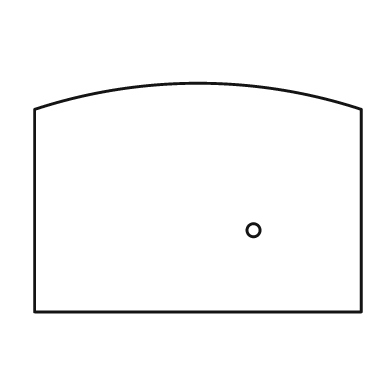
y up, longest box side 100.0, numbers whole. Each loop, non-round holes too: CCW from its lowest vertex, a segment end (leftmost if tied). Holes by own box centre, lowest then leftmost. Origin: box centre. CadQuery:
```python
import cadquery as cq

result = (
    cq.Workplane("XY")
    .moveTo(-50.0, -35.0)
    .lineTo(50.0, -35.0)
    .lineTo(50.0, 27.0)
    .threePointArc((0.0, 35.0), (-50.0, 27.0))
    .close()
    .moveTo(17.0, -10.0)
    .circle(2.0)
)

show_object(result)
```